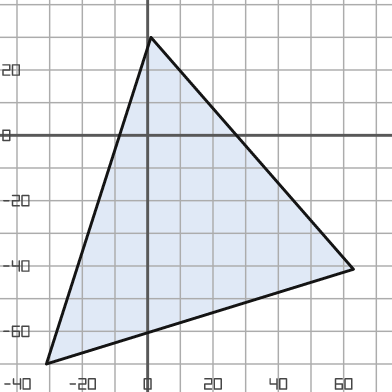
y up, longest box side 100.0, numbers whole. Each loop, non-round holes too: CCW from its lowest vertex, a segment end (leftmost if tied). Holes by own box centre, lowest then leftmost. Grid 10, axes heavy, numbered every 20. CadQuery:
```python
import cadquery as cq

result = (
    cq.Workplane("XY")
    .moveTo(-31.0, -70.0)
    .lineTo(63.0, -41.0)
    .lineTo(1.0, 30.0)
    .close()
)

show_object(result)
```